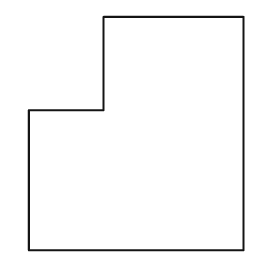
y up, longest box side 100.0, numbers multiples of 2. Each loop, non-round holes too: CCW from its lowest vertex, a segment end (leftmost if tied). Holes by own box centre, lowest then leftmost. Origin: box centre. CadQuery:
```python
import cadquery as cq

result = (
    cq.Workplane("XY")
    .moveTo(-46.0, -50.0)
    .lineTo(46.0, -50.0)
    .lineTo(46.0, 50.0)
    .lineTo(-14.0, 50.0)
    .lineTo(-14.0, 10.0)
    .lineTo(-46.0, 10.0)
    .close()
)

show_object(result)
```